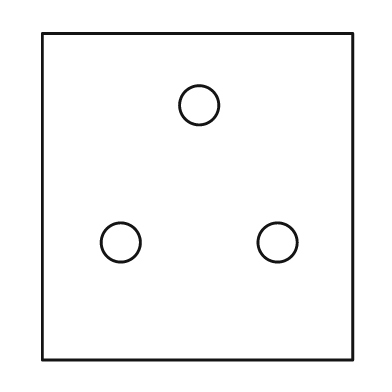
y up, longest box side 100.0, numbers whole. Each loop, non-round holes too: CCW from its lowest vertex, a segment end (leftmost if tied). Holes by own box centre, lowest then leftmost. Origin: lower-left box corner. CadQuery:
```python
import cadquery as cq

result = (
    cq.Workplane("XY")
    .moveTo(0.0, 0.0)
    .lineTo(95.0, 0.0)
    .lineTo(95.0, 100.0)
    .lineTo(0.0, 100.0)
    .close()
    .moveTo(24.0, 36.0)
    .circle(6.0)
    .moveTo(72.0, 36.0)
    .circle(6.0)
    .moveTo(48.0, 78.0)
    .circle(6.0)
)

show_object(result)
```